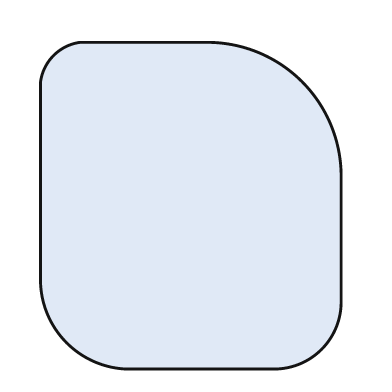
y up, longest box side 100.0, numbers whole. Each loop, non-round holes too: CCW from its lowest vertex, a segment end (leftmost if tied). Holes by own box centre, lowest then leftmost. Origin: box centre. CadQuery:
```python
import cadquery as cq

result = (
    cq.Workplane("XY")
    .moveTo(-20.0, -50.0)
    .lineTo(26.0, -50.0)
    .threePointArc((40.0, -44.0), (46.0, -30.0))
    .lineTo(46.0, 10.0)
    .threePointArc((34.0, 38.0), (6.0, 50.0))
    .lineTo(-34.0, 50.0)
    .threePointArc((-42.0, 46.0), (-46.0, 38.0))
    .lineTo(-46.0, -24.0)
    .threePointArc((-38.0, -42.0), (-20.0, -50.0))
    .close()
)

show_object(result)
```